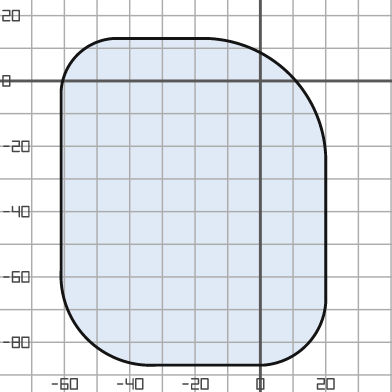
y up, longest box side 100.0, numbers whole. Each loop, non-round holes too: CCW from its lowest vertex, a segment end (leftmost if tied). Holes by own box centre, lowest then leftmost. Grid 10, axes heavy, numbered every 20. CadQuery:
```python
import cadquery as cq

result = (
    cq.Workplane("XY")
    .moveTo(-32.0, -87.0)
    .lineTo(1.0, -87.0)
    .threePointArc((14.0, -81.0), (20.0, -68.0))
    .lineTo(20.0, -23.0)
    .threePointArc((9.0, 2.0), (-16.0, 13.0))
    .lineTo(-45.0, 13.0)
    .threePointArc((-56.0, 8.0), (-61.0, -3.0))
    .lineTo(-61.0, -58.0)
    .threePointArc((-53.0, -79.0), (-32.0, -87.0))
    .close()
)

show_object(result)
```